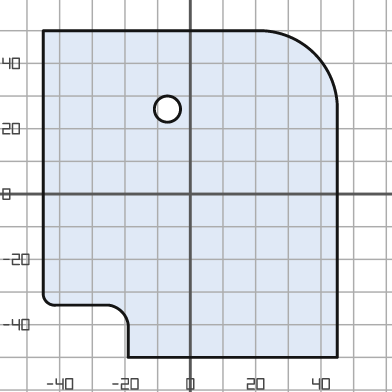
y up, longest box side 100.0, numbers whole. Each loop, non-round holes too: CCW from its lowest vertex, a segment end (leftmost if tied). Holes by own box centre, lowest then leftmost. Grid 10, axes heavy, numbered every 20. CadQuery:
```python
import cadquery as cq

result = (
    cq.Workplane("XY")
    .moveTo(-19.0, -50.0)
    .lineTo(45.0, -50.0)
    .lineTo(45.0, 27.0)
    .threePointArc((38.0, 43.0), (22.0, 50.0))
    .lineTo(-45.0, 50.0)
    .lineTo(-45.0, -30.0)
    .threePointArc((-44.0, -33.0), (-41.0, -34.0))
    .lineTo(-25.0, -34.0)
    .threePointArc((-21.0, -36.0), (-19.0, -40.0))
    .close()
    .moveTo(-7.0, 26.0)
    .circle(4.0)
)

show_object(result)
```